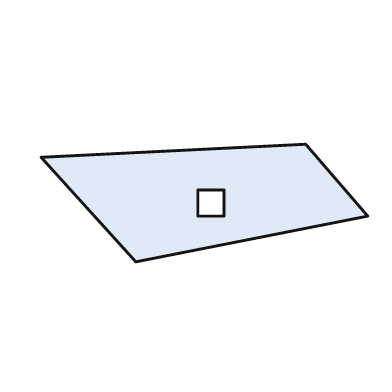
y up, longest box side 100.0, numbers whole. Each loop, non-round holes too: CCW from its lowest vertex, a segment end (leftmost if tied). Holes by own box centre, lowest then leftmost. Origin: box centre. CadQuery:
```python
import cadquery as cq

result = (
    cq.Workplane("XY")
    .moveTo(-21.0, -18.0)
    .lineTo(50.0, -4.0)
    .lineTo(31.0, 18.0)
    .lineTo(-50.0, 14.0)
    .close()
    .moveTo(-2.0, -4.0)
    .lineTo(6.0, -4.0)
    .lineTo(6.0, 4.0)
    .lineTo(-2.0, 4.0)
    .close()
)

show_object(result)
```